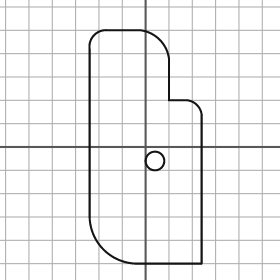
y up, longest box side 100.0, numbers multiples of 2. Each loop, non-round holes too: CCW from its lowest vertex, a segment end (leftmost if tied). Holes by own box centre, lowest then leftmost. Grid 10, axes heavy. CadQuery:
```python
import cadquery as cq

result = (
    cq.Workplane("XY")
    .moveTo(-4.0, -50.0)
    .lineTo(24.0, -50.0)
    .lineTo(24.0, 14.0)
    .threePointArc((22.0, 18.0), (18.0, 20.0))
    .lineTo(10.0, 20.0)
    .lineTo(10.0, 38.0)
    .threePointArc((6.0, 46.0), (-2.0, 50.0))
    .lineTo(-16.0, 50.0)
    .threePointArc((-22.0, 48.0), (-24.0, 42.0))
    .lineTo(-24.0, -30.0)
    .threePointArc((-18.0, -44.0), (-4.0, -50.0))
    .close()
    .moveTo(4.0, -6.0)
    .circle(4.0)
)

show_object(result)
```